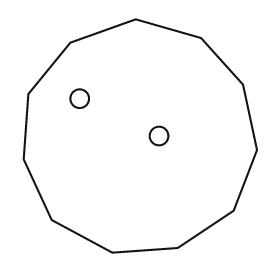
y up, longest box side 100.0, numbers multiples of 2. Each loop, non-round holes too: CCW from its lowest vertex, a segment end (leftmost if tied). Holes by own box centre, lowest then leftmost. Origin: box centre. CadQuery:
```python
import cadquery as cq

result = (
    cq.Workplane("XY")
    .moveTo(-12.0, -50.0)
    .lineTo(16.0, -48.0)
    .lineTo(40.0, -32.0)
    .lineTo(50.0, -6.0)
    .lineTo(44.0, 22.0)
    .lineTo(26.0, 42.0)
    .lineTo(-2.0, 50.0)
    .lineTo(-30.0, 40.0)
    .lineTo(-48.0, 18.0)
    .lineTo(-50.0, -10.0)
    .lineTo(-38.0, -36.0)
    .close()
    .moveTo(8.0, 0.0)
    .circle(4.0)
    .moveTo(-26.0, 16.0)
    .circle(4.0)
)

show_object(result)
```